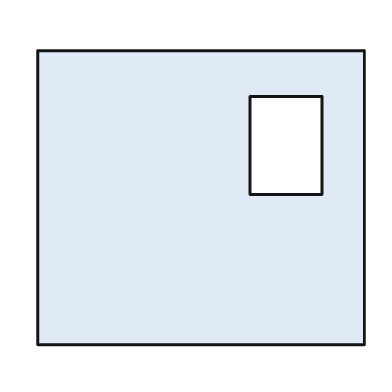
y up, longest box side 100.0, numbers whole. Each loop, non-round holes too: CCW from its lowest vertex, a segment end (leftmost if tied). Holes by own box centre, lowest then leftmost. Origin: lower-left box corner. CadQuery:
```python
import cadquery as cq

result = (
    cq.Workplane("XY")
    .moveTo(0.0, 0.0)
    .lineTo(100.0, 0.0)
    .lineTo(100.0, 90.0)
    .lineTo(0.0, 90.0)
    .close()
    .moveTo(65.0, 46.0)
    .lineTo(87.0, 46.0)
    .lineTo(87.0, 76.0)
    .lineTo(65.0, 76.0)
    .close()
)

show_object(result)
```